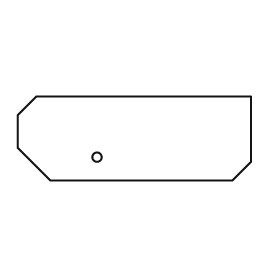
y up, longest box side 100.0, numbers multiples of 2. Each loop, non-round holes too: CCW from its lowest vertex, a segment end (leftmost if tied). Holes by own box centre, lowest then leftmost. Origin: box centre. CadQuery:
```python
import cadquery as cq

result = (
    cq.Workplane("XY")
    .moveTo(-36.0, -18.0)
    .lineTo(42.0, -18.0)
    .lineTo(50.0, -10.0)
    .lineTo(50.0, 18.0)
    .lineTo(-42.0, 18.0)
    .lineTo(-50.0, 10.0)
    .lineTo(-50.0, -4.0)
    .close()
    .moveTo(-16.0, -8.0)
    .circle(2.0)
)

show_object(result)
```